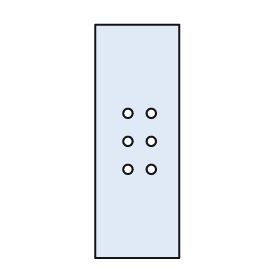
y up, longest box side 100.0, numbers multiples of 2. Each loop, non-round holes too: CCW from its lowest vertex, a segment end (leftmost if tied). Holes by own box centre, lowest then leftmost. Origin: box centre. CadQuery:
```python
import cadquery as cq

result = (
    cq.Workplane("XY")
    .moveTo(-18.0, -50.0)
    .lineTo(18.0, -50.0)
    .lineTo(18.0, 50.0)
    .lineTo(-18.0, 50.0)
    .close()
    .moveTo(-4.0, -12.0)
    .circle(2.0)
    .moveTo(6.0, -12.0)
    .circle(2.0)
    .moveTo(-4.0, 0.0)
    .circle(2.0)
    .moveTo(6.0, 0.0)
    .circle(2.0)
    .moveTo(-4.0, 12.0)
    .circle(2.0)
    .moveTo(6.0, 12.0)
    .circle(2.0)
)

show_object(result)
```